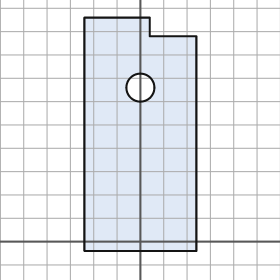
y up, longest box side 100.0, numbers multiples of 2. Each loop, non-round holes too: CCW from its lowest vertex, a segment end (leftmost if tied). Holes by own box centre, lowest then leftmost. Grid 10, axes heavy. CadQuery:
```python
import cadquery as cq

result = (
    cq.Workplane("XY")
    .moveTo(-24.0, -4.0)
    .lineTo(24.0, -4.0)
    .lineTo(24.0, 88.0)
    .lineTo(4.0, 88.0)
    .lineTo(4.0, 96.0)
    .lineTo(-24.0, 96.0)
    .close()
    .moveTo(0.0, 66.0)
    .circle(6.0)
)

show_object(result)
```